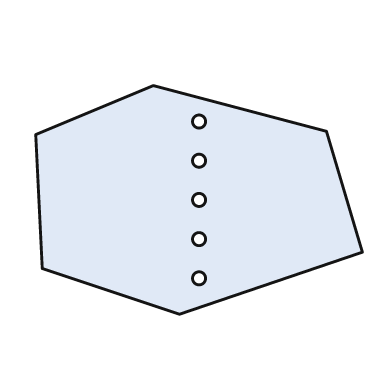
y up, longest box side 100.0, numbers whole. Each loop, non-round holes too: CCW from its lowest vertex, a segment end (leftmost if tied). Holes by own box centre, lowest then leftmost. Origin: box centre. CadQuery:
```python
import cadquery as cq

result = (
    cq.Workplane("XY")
    .moveTo(-6.0, -35.0)
    .lineTo(50.0, -16.0)
    .lineTo(39.0, 21.0)
    .lineTo(-14.0, 35.0)
    .lineTo(-50.0, 20.0)
    .lineTo(-48.0, -21.0)
    .close()
    .moveTo(0.0, -24.0)
    .circle(2.0)
    .moveTo(0.0, -12.0)
    .circle(2.0)
    .moveTo(0.0, 0.0)
    .circle(2.0)
    .moveTo(0.0, 12.0)
    .circle(2.0)
    .moveTo(0.0, 24.0)
    .circle(2.0)
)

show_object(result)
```